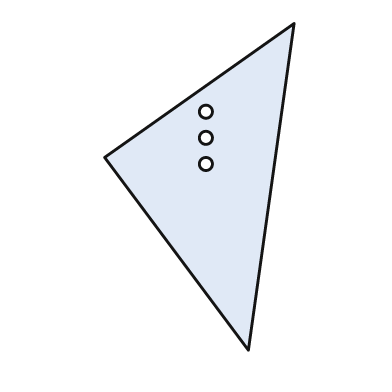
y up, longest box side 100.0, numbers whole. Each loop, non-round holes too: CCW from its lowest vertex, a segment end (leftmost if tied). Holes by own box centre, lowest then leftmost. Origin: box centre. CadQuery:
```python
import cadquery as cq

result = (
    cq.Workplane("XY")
    .moveTo(15.0, -50.0)
    .lineTo(29.0, 50.0)
    .lineTo(-29.0, 9.0)
    .close()
    .moveTo(2.0, 7.0)
    .circle(2.0)
    .moveTo(2.0, 15.0)
    .circle(2.0)
    .moveTo(2.0, 23.0)
    .circle(2.0)
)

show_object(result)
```